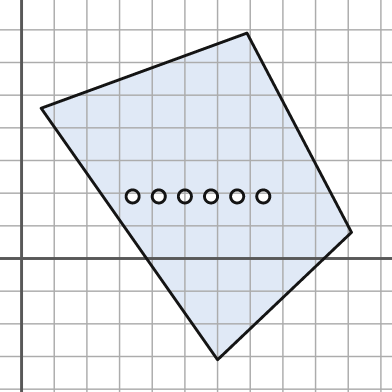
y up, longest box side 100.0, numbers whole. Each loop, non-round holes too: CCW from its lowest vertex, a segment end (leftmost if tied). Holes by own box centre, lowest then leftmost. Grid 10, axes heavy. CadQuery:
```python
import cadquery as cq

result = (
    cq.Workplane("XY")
    .moveTo(60.0, -31.0)
    .lineTo(101.0, 8.0)
    .lineTo(69.0, 69.0)
    .lineTo(6.0, 46.0)
    .close()
    .moveTo(34.0, 19.0)
    .circle(2.0)
    .moveTo(42.0, 19.0)
    .circle(2.0)
    .moveTo(50.0, 19.0)
    .circle(2.0)
    .moveTo(58.0, 19.0)
    .circle(2.0)
    .moveTo(66.0, 19.0)
    .circle(2.0)
    .moveTo(74.0, 19.0)
    .circle(2.0)
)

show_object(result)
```